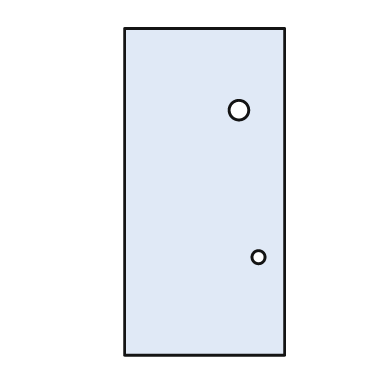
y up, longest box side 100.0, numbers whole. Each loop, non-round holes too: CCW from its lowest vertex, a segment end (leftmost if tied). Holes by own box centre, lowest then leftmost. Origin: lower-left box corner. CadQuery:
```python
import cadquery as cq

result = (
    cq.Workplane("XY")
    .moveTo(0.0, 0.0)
    .lineTo(49.0, 0.0)
    .lineTo(49.0, 100.0)
    .lineTo(0.0, 100.0)
    .close()
    .moveTo(41.0, 30.0)
    .circle(2.0)
    .moveTo(35.0, 75.0)
    .circle(3.0)
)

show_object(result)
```